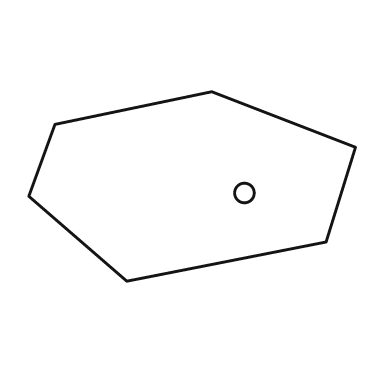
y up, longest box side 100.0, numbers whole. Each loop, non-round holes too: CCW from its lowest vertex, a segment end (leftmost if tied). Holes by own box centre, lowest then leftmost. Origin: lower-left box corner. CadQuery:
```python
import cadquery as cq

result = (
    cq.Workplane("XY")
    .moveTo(30.0, 0.0)
    .lineTo(91.0, 12.0)
    .lineTo(100.0, 41.0)
    .lineTo(56.0, 58.0)
    .lineTo(8.0, 48.0)
    .lineTo(0.0, 26.0)
    .close()
    .moveTo(66.0, 27.0)
    .circle(3.0)
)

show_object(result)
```